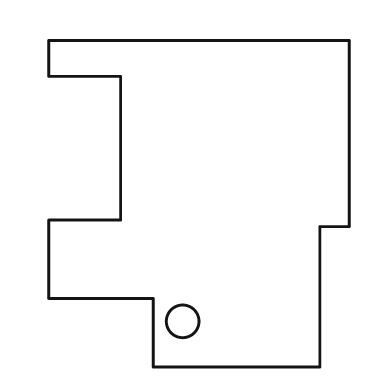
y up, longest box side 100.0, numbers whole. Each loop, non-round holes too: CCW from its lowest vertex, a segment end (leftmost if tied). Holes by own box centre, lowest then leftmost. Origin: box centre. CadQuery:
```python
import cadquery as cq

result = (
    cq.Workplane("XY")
    .moveTo(-14.0, -50.0)
    .lineTo(37.0, -50.0)
    .lineTo(37.0, -7.0)
    .lineTo(46.0, -7.0)
    .lineTo(46.0, 50.0)
    .lineTo(-46.0, 50.0)
    .lineTo(-46.0, 39.0)
    .lineTo(-24.0, 39.0)
    .lineTo(-24.0, -5.0)
    .lineTo(-46.0, -5.0)
    .lineTo(-46.0, -29.0)
    .lineTo(-14.0, -29.0)
    .close()
    .moveTo(-5.0, -36.0)
    .circle(5.0)
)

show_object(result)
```